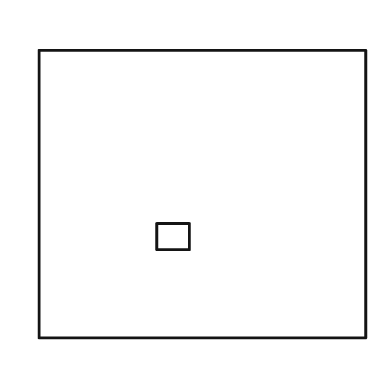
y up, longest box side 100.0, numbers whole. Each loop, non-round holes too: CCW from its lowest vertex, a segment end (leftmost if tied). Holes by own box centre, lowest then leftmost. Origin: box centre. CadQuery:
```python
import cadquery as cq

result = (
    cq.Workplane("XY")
    .moveTo(-50.0, -44.0)
    .lineTo(50.0, -44.0)
    .lineTo(50.0, 44.0)
    .lineTo(-50.0, 44.0)
    .close()
    .moveTo(-14.0, -17.0)
    .lineTo(-4.0, -17.0)
    .lineTo(-4.0, -9.0)
    .lineTo(-14.0, -9.0)
    .close()
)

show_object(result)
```